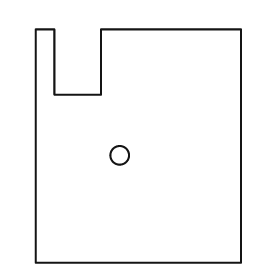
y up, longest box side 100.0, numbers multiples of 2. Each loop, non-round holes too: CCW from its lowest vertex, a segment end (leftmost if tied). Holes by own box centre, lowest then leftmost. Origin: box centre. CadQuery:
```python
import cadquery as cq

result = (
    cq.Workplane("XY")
    .moveTo(-44.0, -50.0)
    .lineTo(44.0, -50.0)
    .lineTo(44.0, 50.0)
    .lineTo(-16.0, 50.0)
    .lineTo(-16.0, 22.0)
    .lineTo(-36.0, 22.0)
    .lineTo(-36.0, 50.0)
    .lineTo(-44.0, 50.0)
    .close()
    .moveTo(-8.0, -4.0)
    .circle(4.0)
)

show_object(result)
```